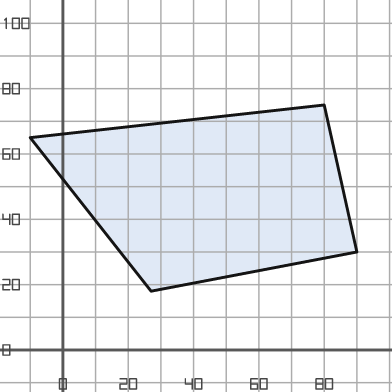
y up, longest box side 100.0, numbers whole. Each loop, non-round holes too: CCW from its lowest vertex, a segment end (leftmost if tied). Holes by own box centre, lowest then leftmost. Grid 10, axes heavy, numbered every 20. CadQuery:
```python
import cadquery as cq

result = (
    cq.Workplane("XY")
    .moveTo(27.0, 18.0)
    .lineTo(90.0, 30.0)
    .lineTo(80.0, 75.0)
    .lineTo(-10.0, 65.0)
    .close()
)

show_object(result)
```